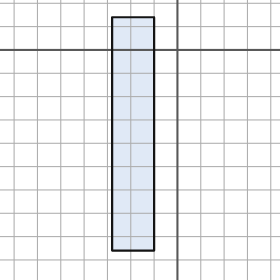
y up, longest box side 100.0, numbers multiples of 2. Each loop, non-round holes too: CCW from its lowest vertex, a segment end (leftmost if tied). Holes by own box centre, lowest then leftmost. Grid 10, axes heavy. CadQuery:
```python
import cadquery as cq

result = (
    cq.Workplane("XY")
    .moveTo(-28.0, -86.0)
    .lineTo(-10.0, -86.0)
    .lineTo(-10.0, 14.0)
    .lineTo(-28.0, 14.0)
    .close()
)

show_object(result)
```